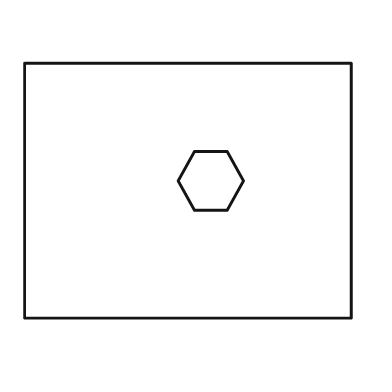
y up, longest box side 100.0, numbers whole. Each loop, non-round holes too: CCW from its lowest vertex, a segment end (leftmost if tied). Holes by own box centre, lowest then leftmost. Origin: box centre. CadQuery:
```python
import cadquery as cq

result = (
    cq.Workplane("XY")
    .moveTo(-50.0, -39.0)
    .lineTo(50.0, -39.0)
    .lineTo(50.0, 39.0)
    .lineTo(-50.0, 39.0)
    .close()
    .moveTo(2.0, -6.0)
    .lineTo(12.0, -6.0)
    .lineTo(17.0, 3.0)
    .lineTo(12.0, 12.0)
    .lineTo(2.0, 12.0)
    .lineTo(-3.0, 3.0)
    .close()
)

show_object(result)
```